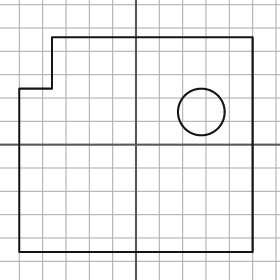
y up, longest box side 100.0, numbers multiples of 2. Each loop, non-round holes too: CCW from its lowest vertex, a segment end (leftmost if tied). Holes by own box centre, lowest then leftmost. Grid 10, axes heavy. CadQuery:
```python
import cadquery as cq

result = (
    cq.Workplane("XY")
    .moveTo(-50.0, -46.0)
    .lineTo(50.0, -46.0)
    .lineTo(50.0, 46.0)
    .lineTo(-36.0, 46.0)
    .lineTo(-36.0, 24.0)
    .lineTo(-50.0, 24.0)
    .close()
    .moveTo(28.0, 14.0)
    .circle(10.0)
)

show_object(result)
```